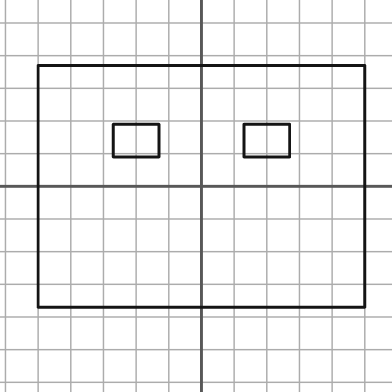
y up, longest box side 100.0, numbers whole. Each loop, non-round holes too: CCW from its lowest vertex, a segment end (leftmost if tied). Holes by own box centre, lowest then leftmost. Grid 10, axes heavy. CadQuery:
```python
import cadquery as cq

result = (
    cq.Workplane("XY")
    .moveTo(-50.0, -37.0)
    .lineTo(50.0, -37.0)
    .lineTo(50.0, 37.0)
    .lineTo(-50.0, 37.0)
    .close()
    .moveTo(-27.0, 9.0)
    .lineTo(-13.0, 9.0)
    .lineTo(-13.0, 19.0)
    .lineTo(-27.0, 19.0)
    .close()
    .moveTo(13.0, 9.0)
    .lineTo(27.0, 9.0)
    .lineTo(27.0, 19.0)
    .lineTo(13.0, 19.0)
    .close()
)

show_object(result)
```